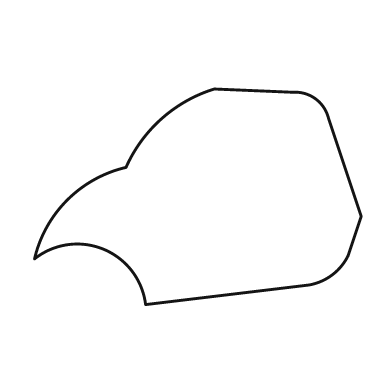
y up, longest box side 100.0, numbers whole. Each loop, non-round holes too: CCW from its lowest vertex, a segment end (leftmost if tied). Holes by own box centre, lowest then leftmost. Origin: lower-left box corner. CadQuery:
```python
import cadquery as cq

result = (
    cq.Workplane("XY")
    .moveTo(34.0, 0.0)
    .lineTo(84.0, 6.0)
    .threePointArc((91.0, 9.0), (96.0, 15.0))
    .lineTo(100.0, 27.0)
    .lineTo(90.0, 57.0)
    .threePointArc((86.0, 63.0), (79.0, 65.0))
    .lineTo(55.0, 66.0)
    .threePointArc((39.0, 57.0), (28.0, 42.0))
    .threePointArc((10.0, 32.0), (0.0, 14.0))
    .threePointArc((21.0, 17.0), (34.0, 0.0))
    .close()
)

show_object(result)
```